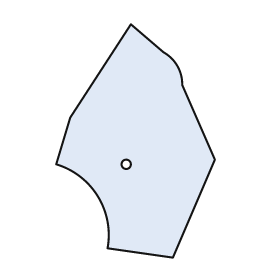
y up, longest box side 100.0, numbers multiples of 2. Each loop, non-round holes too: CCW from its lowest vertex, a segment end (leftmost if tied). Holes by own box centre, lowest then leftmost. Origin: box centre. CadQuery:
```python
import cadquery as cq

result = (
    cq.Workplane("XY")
    .moveTo(16.0, -50.0)
    .lineTo(34.0, -8.0)
    .lineTo(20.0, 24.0)
    .threePointArc((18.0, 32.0), (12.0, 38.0))
    .lineTo(-2.0, 50.0)
    .lineTo(-28.0, 10.0)
    .lineTo(-34.0, -10.0)
    .threePointArc((-16.0, -24.0), (-12.0, -46.0))
    .close()
    .moveTo(-4.0, -10.0)
    .circle(2.0)
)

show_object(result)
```